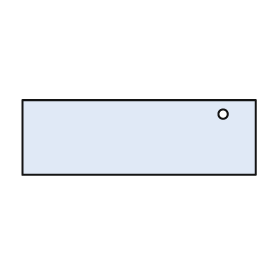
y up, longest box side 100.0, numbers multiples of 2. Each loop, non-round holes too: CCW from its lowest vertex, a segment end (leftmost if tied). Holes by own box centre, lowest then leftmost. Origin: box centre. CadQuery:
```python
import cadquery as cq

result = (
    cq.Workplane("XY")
    .moveTo(-50.0, -16.0)
    .lineTo(50.0, -16.0)
    .lineTo(50.0, 16.0)
    .lineTo(-50.0, 16.0)
    .close()
    .moveTo(36.0, 10.0)
    .circle(2.0)
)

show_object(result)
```